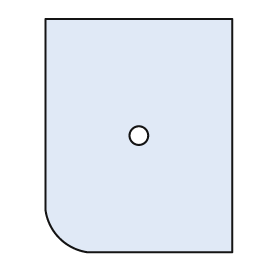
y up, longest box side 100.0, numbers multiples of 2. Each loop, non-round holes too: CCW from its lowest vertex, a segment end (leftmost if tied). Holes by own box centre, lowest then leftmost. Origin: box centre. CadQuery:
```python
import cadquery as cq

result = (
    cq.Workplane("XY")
    .moveTo(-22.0, -50.0)
    .lineTo(40.0, -50.0)
    .lineTo(40.0, 50.0)
    .lineTo(-40.0, 50.0)
    .lineTo(-40.0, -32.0)
    .threePointArc((-34.0, -44.0), (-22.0, -50.0))
    .close()
    .moveTo(0.0, 0.0)
    .circle(4.0)
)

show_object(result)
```